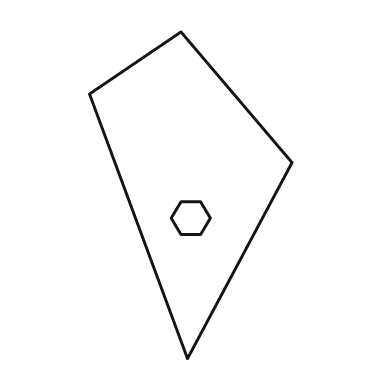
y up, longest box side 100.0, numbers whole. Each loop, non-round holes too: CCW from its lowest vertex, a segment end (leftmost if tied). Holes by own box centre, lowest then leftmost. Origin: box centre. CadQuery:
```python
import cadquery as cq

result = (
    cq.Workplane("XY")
    .moveTo(-1.0, -50.0)
    .lineTo(31.0, 10.0)
    .lineTo(-3.0, 50.0)
    .lineTo(-31.0, 31.0)
    .close()
    .moveTo(-3.0, -12.0)
    .lineTo(3.0, -12.0)
    .lineTo(6.0, -7.0)
    .lineTo(3.0, -2.0)
    .lineTo(-3.0, -2.0)
    .lineTo(-6.0, -7.0)
    .close()
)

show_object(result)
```